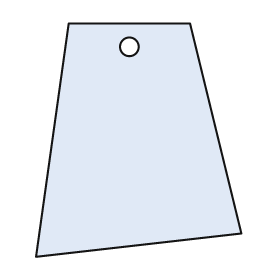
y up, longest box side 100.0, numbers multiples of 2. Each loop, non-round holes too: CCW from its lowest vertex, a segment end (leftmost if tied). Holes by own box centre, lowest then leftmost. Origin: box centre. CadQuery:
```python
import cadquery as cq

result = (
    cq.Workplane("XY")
    .moveTo(-44.0, -50.0)
    .lineTo(44.0, -40.0)
    .lineTo(22.0, 50.0)
    .lineTo(-30.0, 50.0)
    .close()
    .moveTo(-4.0, 40.0)
    .circle(4.0)
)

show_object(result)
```